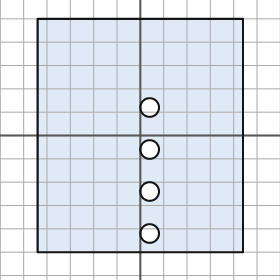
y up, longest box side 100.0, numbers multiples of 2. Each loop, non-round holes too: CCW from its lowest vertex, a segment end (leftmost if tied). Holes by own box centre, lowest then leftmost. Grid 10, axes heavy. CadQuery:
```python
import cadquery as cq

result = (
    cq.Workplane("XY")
    .moveTo(-44.0, -50.0)
    .lineTo(44.0, -50.0)
    .lineTo(44.0, 50.0)
    .lineTo(-44.0, 50.0)
    .close()
    .moveTo(4.0, -42.0)
    .circle(4.0)
    .moveTo(4.0, -24.0)
    .circle(4.0)
    .moveTo(4.0, -6.0)
    .circle(4.0)
    .moveTo(4.0, 12.0)
    .circle(4.0)
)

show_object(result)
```